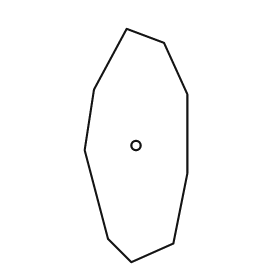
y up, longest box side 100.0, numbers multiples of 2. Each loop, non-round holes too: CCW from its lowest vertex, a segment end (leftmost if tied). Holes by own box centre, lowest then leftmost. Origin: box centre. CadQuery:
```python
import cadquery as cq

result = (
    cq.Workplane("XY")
    .moveTo(-2.0, -50.0)
    .lineTo(16.0, -42.0)
    .lineTo(22.0, -12.0)
    .lineTo(22.0, 22.0)
    .lineTo(12.0, 44.0)
    .lineTo(-4.0, 50.0)
    .lineTo(-18.0, 24.0)
    .lineTo(-22.0, -2.0)
    .lineTo(-12.0, -40.0)
    .close()
    .moveTo(0.0, 0.0)
    .circle(2.0)
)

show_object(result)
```